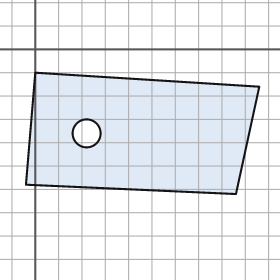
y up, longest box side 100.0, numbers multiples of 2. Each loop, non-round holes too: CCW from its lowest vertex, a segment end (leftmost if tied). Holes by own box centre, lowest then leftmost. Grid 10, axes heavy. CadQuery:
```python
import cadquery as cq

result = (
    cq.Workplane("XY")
    .moveTo(86.0, -62.0)
    .lineTo(96.0, -16.0)
    .lineTo(0.0, -10.0)
    .lineTo(-4.0, -58.0)
    .close()
    .moveTo(22.0, -36.0)
    .circle(6.0)
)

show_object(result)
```